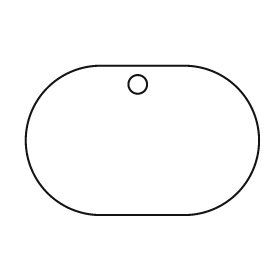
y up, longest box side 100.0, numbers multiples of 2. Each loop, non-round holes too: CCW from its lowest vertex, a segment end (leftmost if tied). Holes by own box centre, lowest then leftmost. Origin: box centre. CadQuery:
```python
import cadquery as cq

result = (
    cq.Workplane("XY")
    .moveTo(-18.0, -32.0)
    .lineTo(18.0, -32.0)
    .threePointArc((50.0, 0.0), (18.0, 32.0))
    .lineTo(-18.0, 32.0)
    .threePointArc((-50.0, 0.0), (-18.0, -32.0))
    .close()
    .moveTo(-2.0, 24.0)
    .circle(4.0)
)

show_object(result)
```